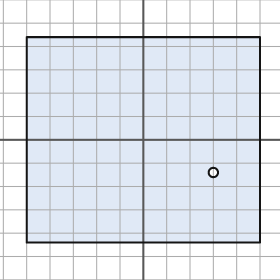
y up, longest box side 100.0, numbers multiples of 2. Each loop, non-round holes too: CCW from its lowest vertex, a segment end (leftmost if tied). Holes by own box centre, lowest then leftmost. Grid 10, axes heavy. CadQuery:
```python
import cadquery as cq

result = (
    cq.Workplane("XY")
    .moveTo(-50.0, -44.0)
    .lineTo(50.0, -44.0)
    .lineTo(50.0, 44.0)
    .lineTo(-50.0, 44.0)
    .close()
    .moveTo(30.0, -14.0)
    .circle(2.0)
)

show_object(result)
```